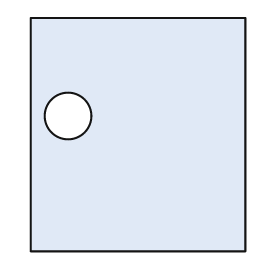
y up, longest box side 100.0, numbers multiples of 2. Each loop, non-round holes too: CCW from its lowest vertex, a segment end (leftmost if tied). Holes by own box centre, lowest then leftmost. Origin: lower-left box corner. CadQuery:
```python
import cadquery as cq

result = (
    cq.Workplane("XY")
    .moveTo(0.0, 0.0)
    .lineTo(92.0, 0.0)
    .lineTo(92.0, 100.0)
    .lineTo(0.0, 100.0)
    .close()
    .moveTo(16.0, 58.0)
    .circle(10.0)
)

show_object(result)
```